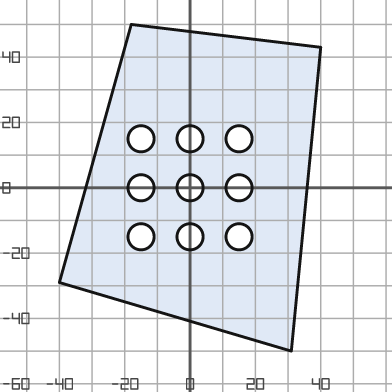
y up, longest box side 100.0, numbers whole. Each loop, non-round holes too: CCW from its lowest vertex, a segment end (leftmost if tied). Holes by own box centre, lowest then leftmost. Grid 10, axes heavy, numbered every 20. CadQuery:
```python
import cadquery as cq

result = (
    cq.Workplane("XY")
    .moveTo(31.0, -50.0)
    .lineTo(40.0, 43.0)
    .lineTo(-18.0, 50.0)
    .lineTo(-40.0, -29.0)
    .close()
    .moveTo(-15.0, -15.0)
    .circle(4.0)
    .moveTo(0.0, -15.0)
    .circle(4.0)
    .moveTo(15.0, -15.0)
    .circle(4.0)
    .moveTo(-15.0, 0.0)
    .circle(4.0)
    .moveTo(0.0, 0.0)
    .circle(4.0)
    .moveTo(15.0, 0.0)
    .circle(4.0)
    .moveTo(-15.0, 15.0)
    .circle(4.0)
    .moveTo(0.0, 15.0)
    .circle(4.0)
    .moveTo(15.0, 15.0)
    .circle(4.0)
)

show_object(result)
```